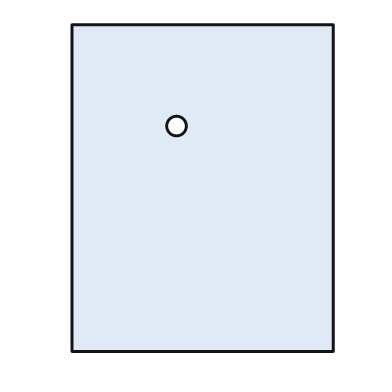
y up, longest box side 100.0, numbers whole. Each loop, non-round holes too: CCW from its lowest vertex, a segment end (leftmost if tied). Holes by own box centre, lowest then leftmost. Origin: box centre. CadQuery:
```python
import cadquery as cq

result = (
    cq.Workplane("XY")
    .moveTo(-40.0, -50.0)
    .lineTo(40.0, -50.0)
    .lineTo(40.0, 50.0)
    .lineTo(-40.0, 50.0)
    .close()
    .moveTo(-8.0, 19.0)
    .circle(3.0)
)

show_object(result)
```